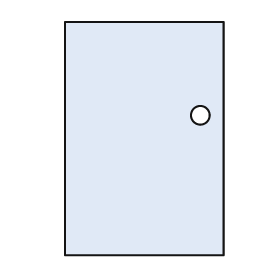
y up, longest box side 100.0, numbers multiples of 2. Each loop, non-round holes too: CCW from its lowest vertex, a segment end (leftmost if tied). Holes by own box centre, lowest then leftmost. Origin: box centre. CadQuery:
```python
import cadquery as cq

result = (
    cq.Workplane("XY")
    .moveTo(-34.0, -50.0)
    .lineTo(34.0, -50.0)
    .lineTo(34.0, 50.0)
    .lineTo(-34.0, 50.0)
    .close()
    .moveTo(24.0, 10.0)
    .circle(4.0)
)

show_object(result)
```